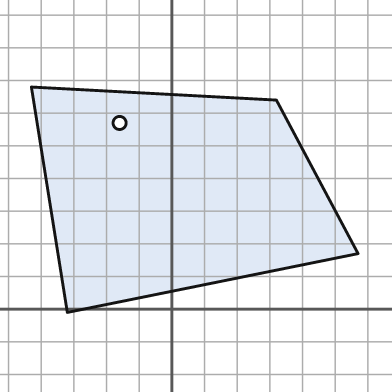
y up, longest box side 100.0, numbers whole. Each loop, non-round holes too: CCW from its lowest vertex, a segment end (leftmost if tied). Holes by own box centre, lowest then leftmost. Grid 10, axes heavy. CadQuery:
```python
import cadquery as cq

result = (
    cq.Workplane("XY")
    .moveTo(-32.0, -1.0)
    .lineTo(57.0, 17.0)
    .lineTo(32.0, 64.0)
    .lineTo(-43.0, 68.0)
    .close()
    .moveTo(-16.0, 57.0)
    .circle(2.0)
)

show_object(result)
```